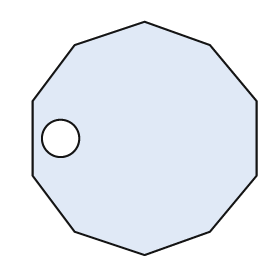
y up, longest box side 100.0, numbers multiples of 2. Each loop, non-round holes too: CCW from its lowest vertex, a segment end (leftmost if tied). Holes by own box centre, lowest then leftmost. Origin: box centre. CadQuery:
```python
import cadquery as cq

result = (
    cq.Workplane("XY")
    .moveTo(0.0, -50.0)
    .lineTo(28.0, -40.0)
    .lineTo(48.0, -16.0)
    .lineTo(48.0, 16.0)
    .lineTo(28.0, 40.0)
    .lineTo(0.0, 50.0)
    .lineTo(-30.0, 40.0)
    .lineTo(-48.0, 16.0)
    .lineTo(-48.0, -16.0)
    .lineTo(-30.0, -40.0)
    .close()
    .moveTo(-36.0, 0.0)
    .circle(8.0)
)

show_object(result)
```